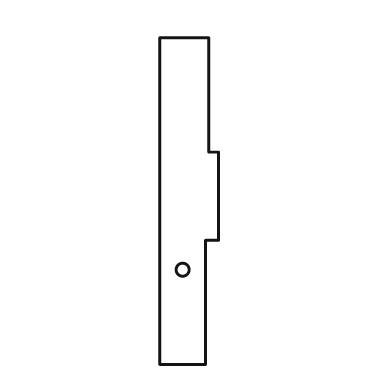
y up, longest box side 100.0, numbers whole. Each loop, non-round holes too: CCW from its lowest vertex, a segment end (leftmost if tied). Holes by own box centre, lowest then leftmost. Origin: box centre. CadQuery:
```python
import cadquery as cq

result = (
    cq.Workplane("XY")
    .moveTo(-9.0, -50.0)
    .lineTo(5.0, -50.0)
    .lineTo(5.0, -12.0)
    .lineTo(9.0, -12.0)
    .lineTo(9.0, 15.0)
    .lineTo(6.0, 15.0)
    .lineTo(6.0, 50.0)
    .lineTo(-9.0, 50.0)
    .close()
    .moveTo(-2.0, -21.0)
    .circle(2.0)
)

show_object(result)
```